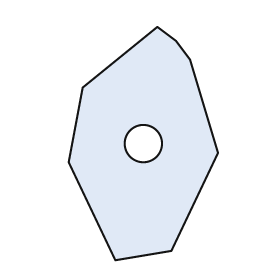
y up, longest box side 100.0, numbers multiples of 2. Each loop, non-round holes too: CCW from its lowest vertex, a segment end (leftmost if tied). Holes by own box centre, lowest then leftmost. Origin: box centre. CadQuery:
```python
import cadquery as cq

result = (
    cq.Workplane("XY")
    .moveTo(-12.0, -50.0)
    .lineTo(12.0, -46.0)
    .lineTo(32.0, -4.0)
    .lineTo(20.0, 36.0)
    .lineTo(14.0, 44.0)
    .lineTo(6.0, 50.0)
    .lineTo(-26.0, 24.0)
    .lineTo(-32.0, -8.0)
    .close()
    .moveTo(0.0, 0.0)
    .circle(8.0)
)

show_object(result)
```